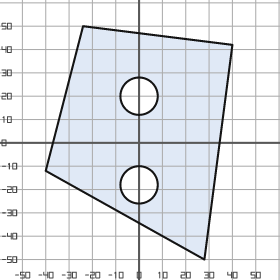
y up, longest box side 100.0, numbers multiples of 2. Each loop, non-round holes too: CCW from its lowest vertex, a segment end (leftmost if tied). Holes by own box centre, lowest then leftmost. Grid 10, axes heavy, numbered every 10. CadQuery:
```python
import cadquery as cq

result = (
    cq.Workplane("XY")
    .moveTo(28.0, -50.0)
    .lineTo(40.0, 42.0)
    .lineTo(-24.0, 50.0)
    .lineTo(-40.0, -12.0)
    .close()
    .moveTo(0.0, -18.0)
    .circle(8.0)
    .moveTo(0.0, 20.0)
    .circle(8.0)
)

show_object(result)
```